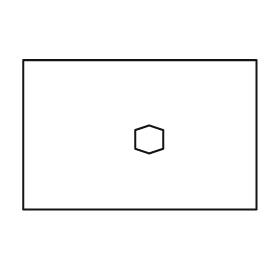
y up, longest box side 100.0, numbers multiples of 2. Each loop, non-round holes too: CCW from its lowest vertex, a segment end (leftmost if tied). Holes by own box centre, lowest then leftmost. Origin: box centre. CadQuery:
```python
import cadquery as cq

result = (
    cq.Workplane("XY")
    .moveTo(-50.0, -32.0)
    .lineTo(50.0, -32.0)
    .lineTo(50.0, 32.0)
    .lineTo(-50.0, 32.0)
    .close()
    .moveTo(4.0, -8.0)
    .lineTo(10.0, -6.0)
    .lineTo(10.0, 2.0)
    .lineTo(4.0, 4.0)
    .lineTo(-2.0, 2.0)
    .lineTo(-2.0, -6.0)
    .close()
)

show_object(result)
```